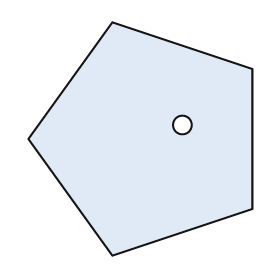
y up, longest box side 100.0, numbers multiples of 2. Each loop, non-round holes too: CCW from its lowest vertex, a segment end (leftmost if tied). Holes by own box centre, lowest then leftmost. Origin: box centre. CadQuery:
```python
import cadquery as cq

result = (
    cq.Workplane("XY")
    .moveTo(-12.0, -50.0)
    .lineTo(48.0, -30.0)
    .lineTo(48.0, 30.0)
    .lineTo(-12.0, 50.0)
    .lineTo(-48.0, 0.0)
    .close()
    .moveTo(18.0, 6.0)
    .circle(4.0)
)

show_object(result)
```